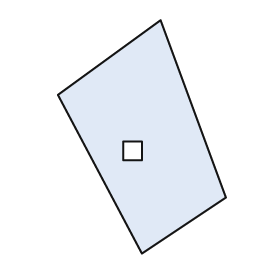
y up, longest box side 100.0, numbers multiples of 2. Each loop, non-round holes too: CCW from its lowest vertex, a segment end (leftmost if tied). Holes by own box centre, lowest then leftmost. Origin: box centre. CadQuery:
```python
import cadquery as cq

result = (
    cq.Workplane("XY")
    .moveTo(0.0, -50.0)
    .lineTo(36.0, -26.0)
    .lineTo(8.0, 50.0)
    .lineTo(-36.0, 18.0)
    .close()
    .moveTo(-8.0, -10.0)
    .lineTo(0.0, -10.0)
    .lineTo(0.0, -2.0)
    .lineTo(-8.0, -2.0)
    .close()
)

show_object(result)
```